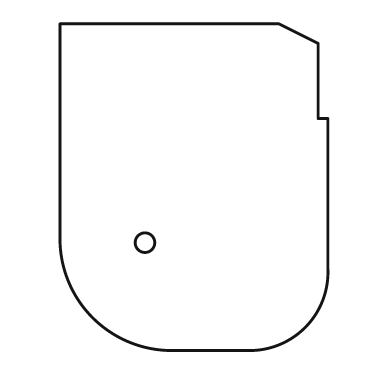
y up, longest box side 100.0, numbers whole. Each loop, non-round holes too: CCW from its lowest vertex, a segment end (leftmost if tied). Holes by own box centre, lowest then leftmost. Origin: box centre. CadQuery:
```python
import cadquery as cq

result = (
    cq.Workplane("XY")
    .moveTo(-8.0, -50.0)
    .lineTo(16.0, -50.0)
    .threePointArc((34.0, -43.0), (41.0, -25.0))
    .lineTo(41.0, 21.0)
    .lineTo(38.0, 21.0)
    .lineTo(38.0, 44.0)
    .lineTo(26.0, 50.0)
    .lineTo(-41.0, 50.0)
    .lineTo(-41.0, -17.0)
    .threePointArc((-31.0, -40.0), (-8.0, -50.0))
    .close()
    .moveTo(-15.0, -17.0)
    .circle(3.0)
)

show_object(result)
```